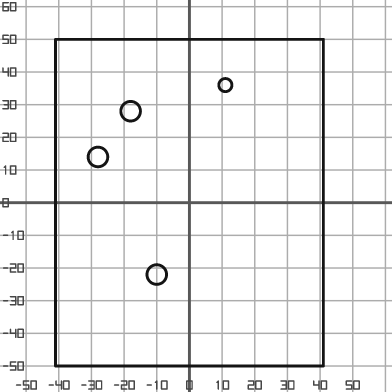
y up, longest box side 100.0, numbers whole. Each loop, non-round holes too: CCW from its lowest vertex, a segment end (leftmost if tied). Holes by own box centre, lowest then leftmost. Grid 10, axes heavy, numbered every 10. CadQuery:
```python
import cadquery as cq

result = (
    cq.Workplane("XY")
    .moveTo(-41.0, -50.0)
    .lineTo(41.0, -50.0)
    .lineTo(41.0, 50.0)
    .lineTo(-41.0, 50.0)
    .close()
    .moveTo(-10.0, -22.0)
    .circle(3.0)
    .moveTo(-28.0, 14.0)
    .circle(3.0)
    .moveTo(-18.0, 28.0)
    .circle(3.0)
    .moveTo(11.0, 36.0)
    .circle(2.0)
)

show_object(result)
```